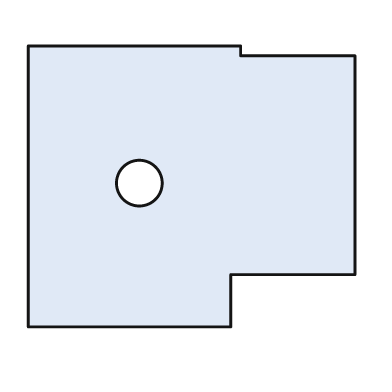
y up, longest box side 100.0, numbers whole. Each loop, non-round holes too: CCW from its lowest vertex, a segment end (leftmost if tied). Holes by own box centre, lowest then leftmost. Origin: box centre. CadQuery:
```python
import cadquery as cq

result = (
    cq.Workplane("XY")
    .moveTo(-50.0, -43.0)
    .lineTo(12.0, -43.0)
    .lineTo(12.0, -27.0)
    .lineTo(50.0, -27.0)
    .lineTo(50.0, 40.0)
    .lineTo(15.0, 40.0)
    .lineTo(15.0, 43.0)
    .lineTo(-50.0, 43.0)
    .close()
    .moveTo(-16.0, 1.0)
    .circle(7.0)
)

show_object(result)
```